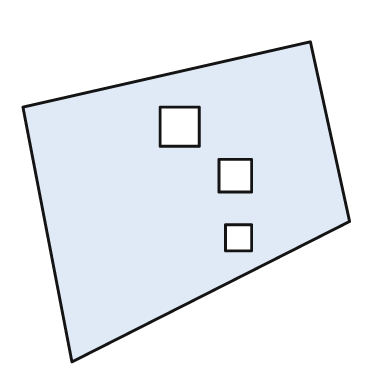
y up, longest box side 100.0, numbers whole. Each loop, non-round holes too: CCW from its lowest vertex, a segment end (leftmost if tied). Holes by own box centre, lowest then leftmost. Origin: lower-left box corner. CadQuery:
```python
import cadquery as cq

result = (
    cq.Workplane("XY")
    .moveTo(15.0, 0.0)
    .lineTo(100.0, 43.0)
    .lineTo(88.0, 98.0)
    .lineTo(0.0, 78.0)
    .close()
    .moveTo(62.0, 34.0)
    .lineTo(70.0, 34.0)
    .lineTo(70.0, 42.0)
    .lineTo(62.0, 42.0)
    .close()
    .moveTo(60.0, 52.0)
    .lineTo(70.0, 52.0)
    .lineTo(70.0, 62.0)
    .lineTo(60.0, 62.0)
    .close()
    .moveTo(42.0, 66.0)
    .lineTo(54.0, 66.0)
    .lineTo(54.0, 78.0)
    .lineTo(42.0, 78.0)
    .close()
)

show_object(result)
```